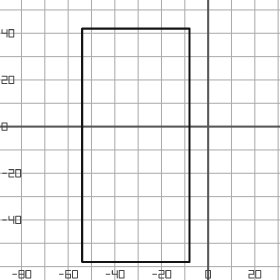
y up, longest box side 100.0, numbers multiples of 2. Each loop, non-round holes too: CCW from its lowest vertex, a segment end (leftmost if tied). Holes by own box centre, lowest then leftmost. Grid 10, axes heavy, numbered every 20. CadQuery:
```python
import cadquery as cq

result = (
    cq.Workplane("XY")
    .moveTo(-54.0, -58.0)
    .lineTo(-8.0, -58.0)
    .lineTo(-8.0, 42.0)
    .lineTo(-54.0, 42.0)
    .close()
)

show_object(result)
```